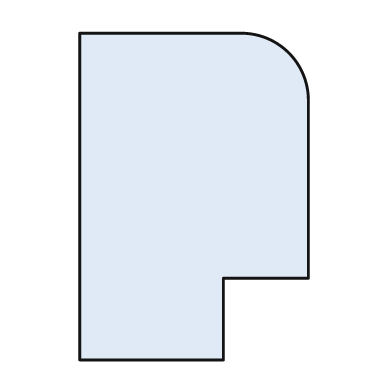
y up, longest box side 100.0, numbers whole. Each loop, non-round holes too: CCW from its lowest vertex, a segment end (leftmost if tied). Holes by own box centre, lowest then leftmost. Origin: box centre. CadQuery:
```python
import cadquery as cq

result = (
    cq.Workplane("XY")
    .moveTo(-35.0, -50.0)
    .lineTo(9.0, -50.0)
    .lineTo(9.0, -25.0)
    .lineTo(35.0, -25.0)
    .lineTo(35.0, 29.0)
    .threePointArc((29.0, 44.0), (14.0, 50.0))
    .lineTo(-35.0, 50.0)
    .close()
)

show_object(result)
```